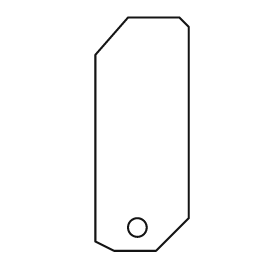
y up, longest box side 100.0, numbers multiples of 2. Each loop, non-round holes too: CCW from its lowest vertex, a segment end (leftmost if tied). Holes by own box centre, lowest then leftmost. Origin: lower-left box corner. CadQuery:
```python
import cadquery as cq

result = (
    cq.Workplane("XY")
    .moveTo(8.0, 0.0)
    .lineTo(26.0, 0.0)
    .lineTo(40.0, 14.0)
    .lineTo(40.0, 96.0)
    .lineTo(36.0, 100.0)
    .lineTo(14.0, 100.0)
    .lineTo(0.0, 84.0)
    .lineTo(0.0, 4.0)
    .close()
    .moveTo(18.0, 10.0)
    .circle(4.0)
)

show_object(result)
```